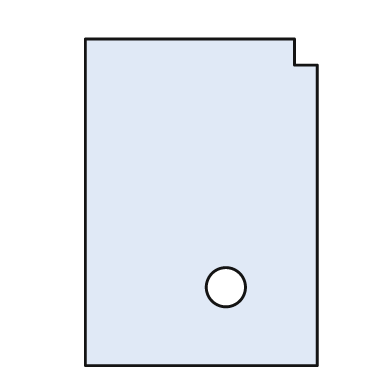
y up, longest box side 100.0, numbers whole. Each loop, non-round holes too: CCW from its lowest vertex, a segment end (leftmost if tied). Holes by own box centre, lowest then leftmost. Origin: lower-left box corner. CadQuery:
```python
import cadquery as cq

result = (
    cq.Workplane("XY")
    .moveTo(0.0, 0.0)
    .lineTo(71.0, 0.0)
    .lineTo(71.0, 92.0)
    .lineTo(64.0, 92.0)
    .lineTo(64.0, 100.0)
    .lineTo(0.0, 100.0)
    .close()
    .moveTo(43.0, 24.0)
    .circle(6.0)
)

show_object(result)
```